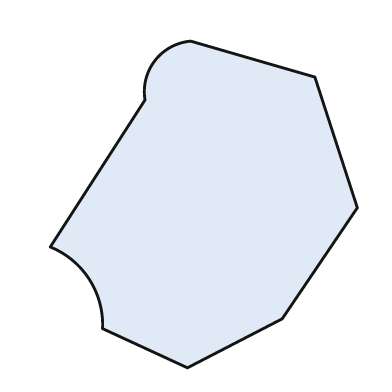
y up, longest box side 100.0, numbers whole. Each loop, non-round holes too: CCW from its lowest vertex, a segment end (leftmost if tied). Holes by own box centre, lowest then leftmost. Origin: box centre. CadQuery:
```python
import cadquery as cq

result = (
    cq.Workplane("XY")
    .moveTo(-5.0, -50.0)
    .lineTo(24.0, -35.0)
    .lineTo(47.0, -1.0)
    .lineTo(34.0, 39.0)
    .lineTo(-4.0, 50.0)
    .threePointArc((-15.0, 44.0), (-18.0, 32.0))
    .lineTo(-47.0, -13.0)
    .threePointArc((-35.0, -23.0), (-31.0, -38.0))
    .close()
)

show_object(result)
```